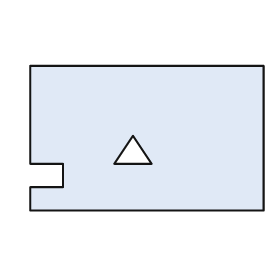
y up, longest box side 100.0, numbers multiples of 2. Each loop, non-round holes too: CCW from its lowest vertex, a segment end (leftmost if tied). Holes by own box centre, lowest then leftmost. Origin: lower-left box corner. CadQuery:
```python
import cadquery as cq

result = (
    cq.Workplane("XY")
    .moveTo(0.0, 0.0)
    .lineTo(100.0, 0.0)
    .lineTo(100.0, 62.0)
    .lineTo(0.0, 62.0)
    .lineTo(0.0, 20.0)
    .lineTo(14.0, 20.0)
    .lineTo(14.0, 10.0)
    .lineTo(0.0, 10.0)
    .close()
    .moveTo(36.0, 20.0)
    .lineTo(52.0, 20.0)
    .lineTo(44.0, 32.0)
    .close()
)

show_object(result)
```